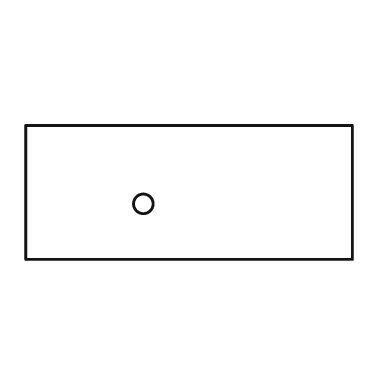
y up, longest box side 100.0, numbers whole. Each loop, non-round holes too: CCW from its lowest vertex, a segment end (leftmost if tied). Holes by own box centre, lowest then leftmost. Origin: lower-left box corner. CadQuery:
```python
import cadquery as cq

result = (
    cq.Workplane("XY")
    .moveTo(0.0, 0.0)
    .lineTo(100.0, 0.0)
    .lineTo(100.0, 41.0)
    .lineTo(0.0, 41.0)
    .close()
    .moveTo(36.0, 17.0)
    .circle(3.0)
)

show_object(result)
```